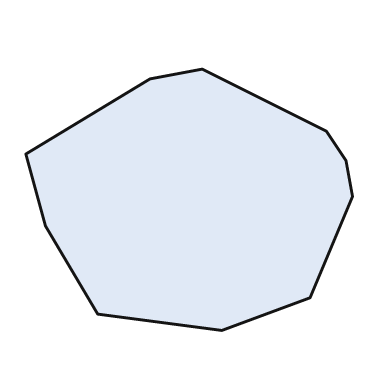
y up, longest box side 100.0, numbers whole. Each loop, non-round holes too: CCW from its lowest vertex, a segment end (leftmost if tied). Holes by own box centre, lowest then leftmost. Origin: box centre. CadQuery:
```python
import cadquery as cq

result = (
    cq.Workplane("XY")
    .moveTo(10.0, -40.0)
    .lineTo(37.0, -30.0)
    .lineTo(50.0, 1.0)
    .lineTo(48.0, 12.0)
    .lineTo(42.0, 21.0)
    .lineTo(4.0, 40.0)
    .lineTo(-12.0, 37.0)
    .lineTo(-50.0, 14.0)
    .lineTo(-44.0, -8.0)
    .lineTo(-28.0, -35.0)
    .close()
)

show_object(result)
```